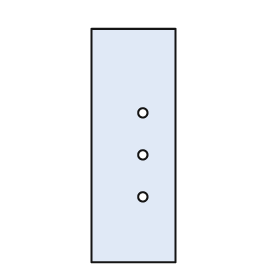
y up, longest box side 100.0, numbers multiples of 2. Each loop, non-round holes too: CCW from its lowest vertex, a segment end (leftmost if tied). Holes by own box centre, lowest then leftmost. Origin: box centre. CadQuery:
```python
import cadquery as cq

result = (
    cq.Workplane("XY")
    .moveTo(-18.0, -50.0)
    .lineTo(18.0, -50.0)
    .lineTo(18.0, 50.0)
    .lineTo(-18.0, 50.0)
    .close()
    .moveTo(4.0, -22.0)
    .circle(2.0)
    .moveTo(4.0, -4.0)
    .circle(2.0)
    .moveTo(4.0, 14.0)
    .circle(2.0)
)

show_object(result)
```